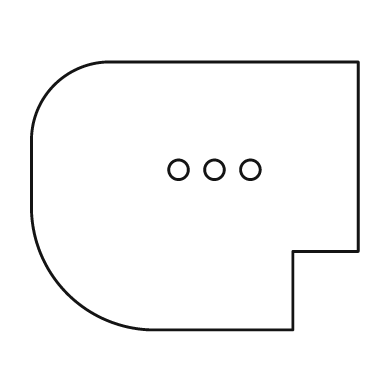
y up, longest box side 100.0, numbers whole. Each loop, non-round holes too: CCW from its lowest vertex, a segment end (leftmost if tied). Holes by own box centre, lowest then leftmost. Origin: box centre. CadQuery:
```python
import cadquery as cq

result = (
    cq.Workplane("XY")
    .moveTo(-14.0, -41.0)
    .lineTo(30.0, -41.0)
    .lineTo(30.0, -17.0)
    .lineTo(50.0, -17.0)
    .lineTo(50.0, 41.0)
    .lineTo(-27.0, 41.0)
    .threePointArc((-43.0, 34.0), (-50.0, 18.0))
    .lineTo(-50.0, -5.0)
    .threePointArc((-39.0, -30.0), (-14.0, -41.0))
    .close()
    .moveTo(-5.0, 8.0)
    .circle(3.0)
    .moveTo(6.0, 8.0)
    .circle(3.0)
    .moveTo(17.0, 8.0)
    .circle(3.0)
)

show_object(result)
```